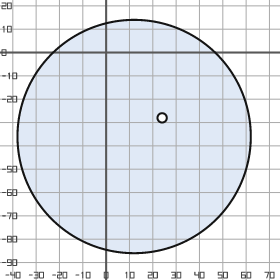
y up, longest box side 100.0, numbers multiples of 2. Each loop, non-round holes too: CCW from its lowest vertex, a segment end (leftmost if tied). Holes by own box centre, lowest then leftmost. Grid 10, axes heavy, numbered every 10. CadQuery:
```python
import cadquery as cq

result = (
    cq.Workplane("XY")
    .moveTo(12.0, -36.0)
    .circle(50.0)
    .moveTo(24.0, -28.0)
    .circle(2.0)
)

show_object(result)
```